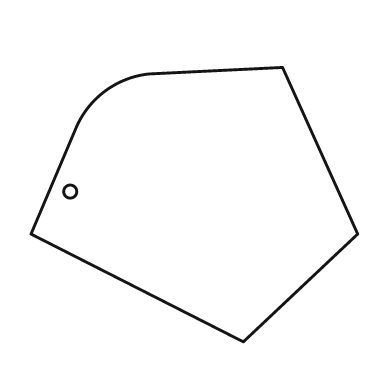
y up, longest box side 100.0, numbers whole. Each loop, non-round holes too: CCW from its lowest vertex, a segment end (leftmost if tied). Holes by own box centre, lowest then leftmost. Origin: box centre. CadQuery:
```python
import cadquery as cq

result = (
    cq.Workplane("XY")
    .moveTo(15.0, -42.0)
    .lineTo(50.0, -9.0)
    .lineTo(27.0, 42.0)
    .lineTo(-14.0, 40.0)
    .threePointArc((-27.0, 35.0), (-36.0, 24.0))
    .lineTo(-50.0, -9.0)
    .close()
    .moveTo(-38.0, 4.0)
    .circle(2.0)
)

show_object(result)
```